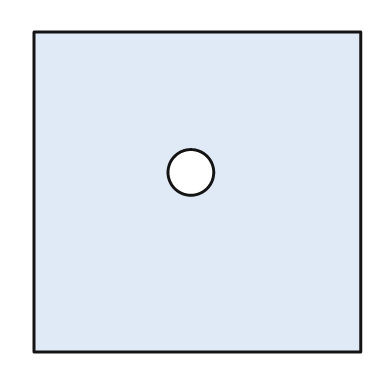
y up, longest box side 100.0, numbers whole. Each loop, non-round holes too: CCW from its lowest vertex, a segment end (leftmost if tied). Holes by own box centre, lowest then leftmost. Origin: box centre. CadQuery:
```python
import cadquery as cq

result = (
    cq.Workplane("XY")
    .moveTo(-50.0, -49.0)
    .lineTo(50.0, -49.0)
    .lineTo(50.0, 49.0)
    .lineTo(-50.0, 49.0)
    .close()
    .moveTo(-2.0, 6.0)
    .circle(7.0)
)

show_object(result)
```